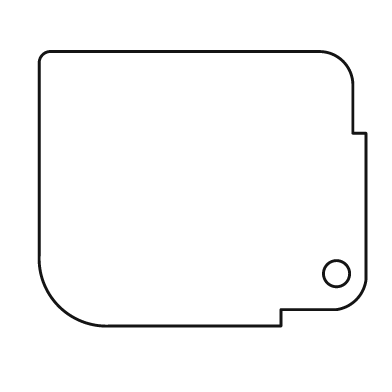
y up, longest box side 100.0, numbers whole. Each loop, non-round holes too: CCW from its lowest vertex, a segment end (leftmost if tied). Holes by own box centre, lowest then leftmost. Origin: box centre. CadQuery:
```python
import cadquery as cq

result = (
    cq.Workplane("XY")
    .moveTo(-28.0, -42.0)
    .lineTo(24.0, -42.0)
    .lineTo(24.0, -37.0)
    .lineTo(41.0, -37.0)
    .threePointArc((47.0, -34.0), (50.0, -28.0))
    .lineTo(50.0, 17.0)
    .lineTo(46.0, 17.0)
    .lineTo(46.0, 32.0)
    .threePointArc((43.0, 39.0), (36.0, 42.0))
    .lineTo(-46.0, 42.0)
    .threePointArc((-49.0, 41.0), (-50.0, 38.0))
    .lineTo(-50.0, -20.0)
    .threePointArc((-44.0, -36.0), (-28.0, -42.0))
    .close()
    .moveTo(41.0, -26.0)
    .circle(4.0)
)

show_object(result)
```